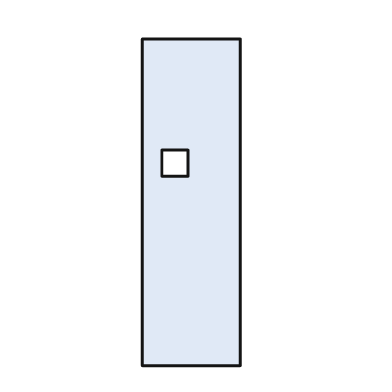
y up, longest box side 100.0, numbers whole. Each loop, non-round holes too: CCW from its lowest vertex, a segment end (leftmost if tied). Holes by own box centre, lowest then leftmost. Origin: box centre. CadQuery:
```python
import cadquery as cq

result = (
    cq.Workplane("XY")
    .moveTo(-15.0, -50.0)
    .lineTo(15.0, -50.0)
    .lineTo(15.0, 50.0)
    .lineTo(-15.0, 50.0)
    .close()
    .moveTo(-9.0, 8.0)
    .lineTo(-1.0, 8.0)
    .lineTo(-1.0, 16.0)
    .lineTo(-9.0, 16.0)
    .close()
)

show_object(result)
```